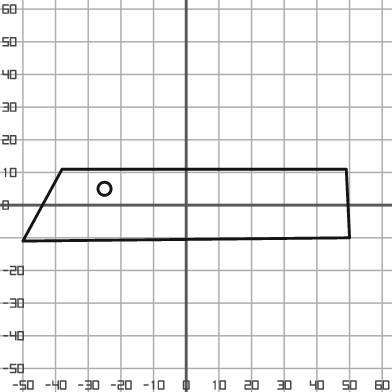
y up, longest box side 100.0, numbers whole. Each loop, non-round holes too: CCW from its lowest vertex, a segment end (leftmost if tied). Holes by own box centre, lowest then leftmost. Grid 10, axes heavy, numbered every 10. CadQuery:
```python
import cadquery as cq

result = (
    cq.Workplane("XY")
    .moveTo(-50.0, -11.0)
    .lineTo(50.0, -10.0)
    .lineTo(49.0, 11.0)
    .lineTo(-38.0, 11.0)
    .close()
    .moveTo(-25.0, 5.0)
    .circle(2.0)
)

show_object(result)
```